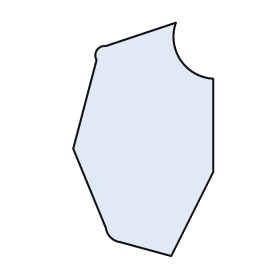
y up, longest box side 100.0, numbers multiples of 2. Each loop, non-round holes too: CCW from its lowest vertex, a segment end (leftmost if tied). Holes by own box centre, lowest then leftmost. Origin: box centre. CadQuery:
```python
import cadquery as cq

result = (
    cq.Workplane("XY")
    .moveTo(12.0, -50.0)
    .lineTo(30.0, -14.0)
    .lineTo(30.0, 26.0)
    .threePointArc((16.0, 34.0), (14.0, 50.0))
    .lineTo(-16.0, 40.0)
    .threePointArc((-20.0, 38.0), (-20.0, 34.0))
    .lineTo(-30.0, -4.0)
    .lineTo(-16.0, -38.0)
    .threePointArc((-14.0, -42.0), (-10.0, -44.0))
    .close()
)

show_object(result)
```